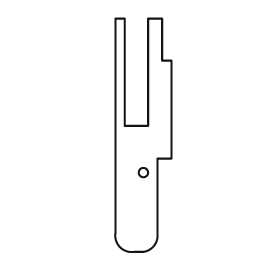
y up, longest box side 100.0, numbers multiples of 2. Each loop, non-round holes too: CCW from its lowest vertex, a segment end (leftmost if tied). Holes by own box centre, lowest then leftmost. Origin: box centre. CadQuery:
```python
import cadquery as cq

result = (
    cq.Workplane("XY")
    .moveTo(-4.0, -50.0)
    .lineTo(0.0, -50.0)
    .threePointArc((4.0, -48.0), (6.0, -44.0))
    .lineTo(6.0, -10.0)
    .lineTo(12.0, -10.0)
    .lineTo(12.0, 32.0)
    .lineTo(8.0, 32.0)
    .lineTo(8.0, 50.0)
    .lineTo(2.0, 50.0)
    .lineTo(2.0, 4.0)
    .lineTo(-8.0, 4.0)
    .lineTo(-8.0, 50.0)
    .lineTo(-12.0, 50.0)
    .lineTo(-12.0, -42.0)
    .threePointArc((-10.0, -48.0), (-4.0, -50.0))
    .close()
    .moveTo(0.0, -16.0)
    .circle(2.0)
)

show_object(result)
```